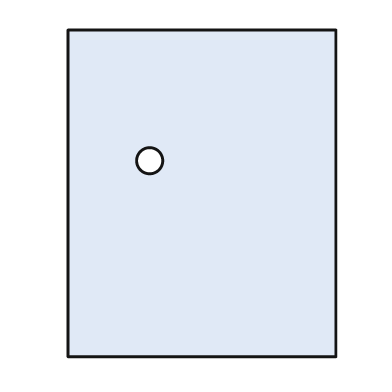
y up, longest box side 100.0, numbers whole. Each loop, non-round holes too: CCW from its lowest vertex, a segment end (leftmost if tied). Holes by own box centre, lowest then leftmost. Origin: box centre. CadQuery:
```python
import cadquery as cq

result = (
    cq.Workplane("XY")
    .moveTo(-41.0, -50.0)
    .lineTo(41.0, -50.0)
    .lineTo(41.0, 50.0)
    .lineTo(-41.0, 50.0)
    .close()
    .moveTo(-16.0, 10.0)
    .circle(4.0)
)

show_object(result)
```